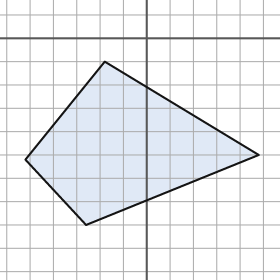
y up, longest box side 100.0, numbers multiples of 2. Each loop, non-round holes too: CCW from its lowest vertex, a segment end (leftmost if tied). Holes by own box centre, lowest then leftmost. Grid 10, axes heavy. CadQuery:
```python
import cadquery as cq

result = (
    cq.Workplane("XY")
    .moveTo(-26.0, -80.0)
    .lineTo(48.0, -50.0)
    .lineTo(-18.0, -10.0)
    .lineTo(-52.0, -52.0)
    .close()
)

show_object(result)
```